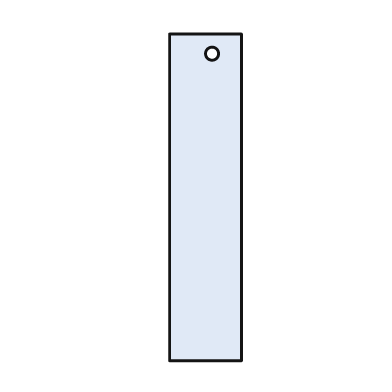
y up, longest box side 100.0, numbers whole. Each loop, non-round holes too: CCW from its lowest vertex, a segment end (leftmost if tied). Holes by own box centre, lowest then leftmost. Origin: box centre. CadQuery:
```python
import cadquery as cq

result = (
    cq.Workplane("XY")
    .moveTo(-11.0, -50.0)
    .lineTo(11.0, -50.0)
    .lineTo(11.0, 50.0)
    .lineTo(-11.0, 50.0)
    .close()
    .moveTo(2.0, 44.0)
    .circle(2.0)
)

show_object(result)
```